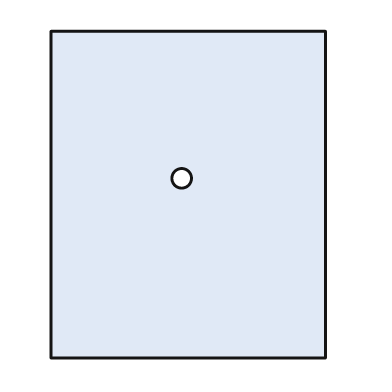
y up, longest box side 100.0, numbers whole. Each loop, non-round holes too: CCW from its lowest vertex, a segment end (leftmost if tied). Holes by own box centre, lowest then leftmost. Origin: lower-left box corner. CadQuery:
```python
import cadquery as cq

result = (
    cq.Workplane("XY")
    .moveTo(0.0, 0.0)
    .lineTo(84.0, 0.0)
    .lineTo(84.0, 100.0)
    .lineTo(0.0, 100.0)
    .close()
    .moveTo(40.0, 55.0)
    .circle(3.0)
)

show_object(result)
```